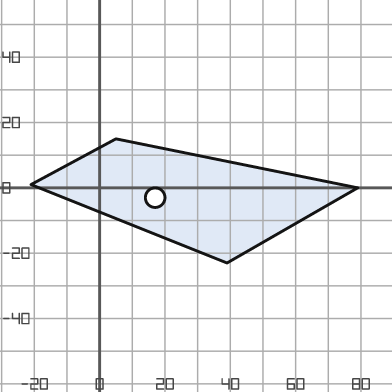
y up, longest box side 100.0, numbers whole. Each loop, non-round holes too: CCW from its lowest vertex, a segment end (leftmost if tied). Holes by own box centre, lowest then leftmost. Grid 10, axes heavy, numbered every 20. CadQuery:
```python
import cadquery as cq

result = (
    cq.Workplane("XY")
    .moveTo(39.0, -23.0)
    .lineTo(79.0, 0.0)
    .lineTo(5.0, 15.0)
    .lineTo(-21.0, 1.0)
    .close()
    .moveTo(17.0, -3.0)
    .circle(3.0)
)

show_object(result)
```